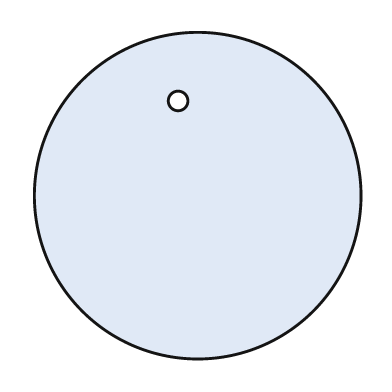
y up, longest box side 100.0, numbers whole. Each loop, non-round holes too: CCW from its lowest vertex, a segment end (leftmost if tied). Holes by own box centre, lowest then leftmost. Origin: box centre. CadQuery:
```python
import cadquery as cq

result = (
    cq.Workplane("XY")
    .moveTo(0.0, 0.0)
    .circle(50.0)
    .moveTo(-6.0, 29.0)
    .circle(3.0)
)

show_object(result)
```